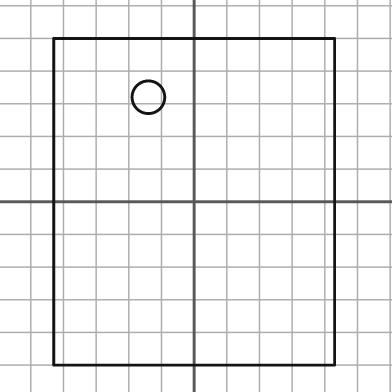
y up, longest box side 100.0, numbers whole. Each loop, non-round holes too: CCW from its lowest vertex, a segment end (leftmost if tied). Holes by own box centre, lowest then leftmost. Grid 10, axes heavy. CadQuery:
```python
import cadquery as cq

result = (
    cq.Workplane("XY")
    .moveTo(-43.0, -50.0)
    .lineTo(43.0, -50.0)
    .lineTo(43.0, 50.0)
    .lineTo(-43.0, 50.0)
    .close()
    .moveTo(-14.0, 32.0)
    .circle(5.0)
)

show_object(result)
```